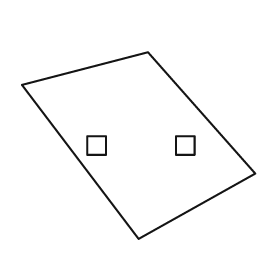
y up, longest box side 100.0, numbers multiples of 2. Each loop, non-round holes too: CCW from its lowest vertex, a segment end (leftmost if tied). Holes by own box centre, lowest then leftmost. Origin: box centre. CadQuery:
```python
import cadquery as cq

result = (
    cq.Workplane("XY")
    .moveTo(0.0, -40.0)
    .lineTo(50.0, -12.0)
    .lineTo(4.0, 40.0)
    .lineTo(-50.0, 26.0)
    .close()
    .moveTo(-22.0, -4.0)
    .lineTo(-14.0, -4.0)
    .lineTo(-14.0, 4.0)
    .lineTo(-22.0, 4.0)
    .close()
    .moveTo(16.0, -4.0)
    .lineTo(24.0, -4.0)
    .lineTo(24.0, 4.0)
    .lineTo(16.0, 4.0)
    .close()
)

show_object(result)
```